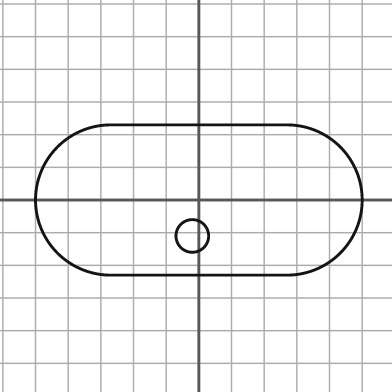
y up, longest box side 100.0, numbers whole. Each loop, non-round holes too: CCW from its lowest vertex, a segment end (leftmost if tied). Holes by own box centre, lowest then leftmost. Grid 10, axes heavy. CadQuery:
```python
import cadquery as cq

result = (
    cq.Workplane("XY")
    .moveTo(-27.0, -23.0)
    .lineTo(27.0, -23.0)
    .threePointArc((50.0, 0.0), (27.0, 23.0))
    .lineTo(-27.0, 23.0)
    .threePointArc((-50.0, 0.0), (-27.0, -23.0))
    .close()
    .moveTo(-2.0, -11.0)
    .circle(5.0)
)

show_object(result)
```